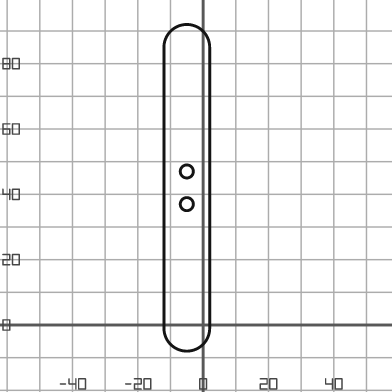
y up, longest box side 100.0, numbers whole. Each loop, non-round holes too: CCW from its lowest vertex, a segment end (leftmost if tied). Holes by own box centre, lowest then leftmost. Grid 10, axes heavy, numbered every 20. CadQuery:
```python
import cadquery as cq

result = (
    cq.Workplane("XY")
    .moveTo(-12.0, -1.0)
    .threePointArc((-5.0, -8.0), (2.0, -1.0))
    .lineTo(2.0, 85.0)
    .threePointArc((-5.0, 92.0), (-12.0, 85.0))
    .close()
    .moveTo(-5.0, 37.0)
    .circle(2.0)
    .moveTo(-5.0, 47.0)
    .circle(2.0)
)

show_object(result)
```